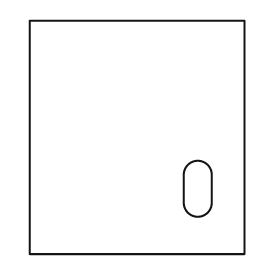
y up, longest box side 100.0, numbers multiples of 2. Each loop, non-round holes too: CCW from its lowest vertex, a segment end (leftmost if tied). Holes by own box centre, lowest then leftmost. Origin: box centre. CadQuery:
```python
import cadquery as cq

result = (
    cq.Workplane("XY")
    .moveTo(-46.0, -50.0)
    .lineTo(46.0, -50.0)
    .lineTo(46.0, 50.0)
    .lineTo(-46.0, 50.0)
    .close()
    .moveTo(20.0, -28.0)
    .threePointArc((26.0, -34.0), (32.0, -28.0))
    .lineTo(32.0, -16.0)
    .threePointArc((26.0, -10.0), (20.0, -16.0))
    .close()
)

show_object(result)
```